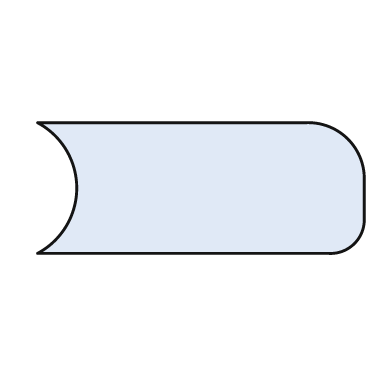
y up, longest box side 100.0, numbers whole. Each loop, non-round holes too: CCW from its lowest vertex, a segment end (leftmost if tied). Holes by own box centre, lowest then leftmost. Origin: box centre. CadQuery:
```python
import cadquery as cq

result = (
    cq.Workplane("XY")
    .moveTo(-50.0, -20.0)
    .lineTo(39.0, -20.0)
    .threePointArc((47.0, -17.0), (50.0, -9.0))
    .lineTo(50.0, 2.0)
    .threePointArc((45.0, 15.0), (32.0, 20.0))
    .lineTo(-50.0, 20.0)
    .threePointArc((-38.0, 0.0), (-50.0, -20.0))
    .close()
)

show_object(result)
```